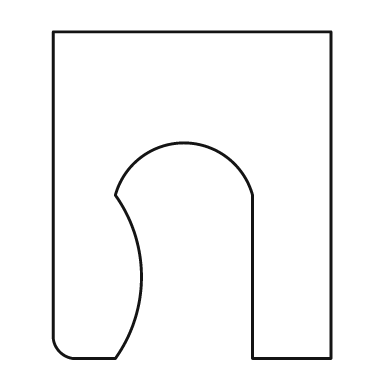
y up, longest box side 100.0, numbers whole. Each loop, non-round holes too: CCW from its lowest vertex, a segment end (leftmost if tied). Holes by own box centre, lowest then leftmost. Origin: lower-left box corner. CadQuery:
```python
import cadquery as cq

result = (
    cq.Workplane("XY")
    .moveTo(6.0, 0.0)
    .lineTo(19.0, 0.0)
    .threePointArc((27.0, 25.0), (19.0, 50.0))
    .threePointArc((40.0, 66.0), (61.0, 50.0))
    .lineTo(61.0, 0.0)
    .lineTo(85.0, 0.0)
    .lineTo(85.0, 100.0)
    .lineTo(0.0, 100.0)
    .lineTo(0.0, 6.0)
    .threePointArc((2.0, 2.0), (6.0, 0.0))
    .close()
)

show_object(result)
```